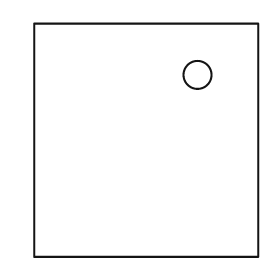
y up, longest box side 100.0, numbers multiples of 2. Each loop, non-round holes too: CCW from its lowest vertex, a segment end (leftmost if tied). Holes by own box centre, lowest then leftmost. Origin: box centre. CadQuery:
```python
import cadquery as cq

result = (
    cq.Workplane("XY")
    .moveTo(-48.0, -50.0)
    .lineTo(48.0, -50.0)
    .lineTo(48.0, 50.0)
    .lineTo(-48.0, 50.0)
    .close()
    .moveTo(22.0, 28.0)
    .circle(6.0)
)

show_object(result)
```